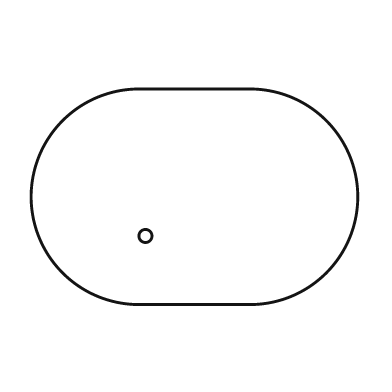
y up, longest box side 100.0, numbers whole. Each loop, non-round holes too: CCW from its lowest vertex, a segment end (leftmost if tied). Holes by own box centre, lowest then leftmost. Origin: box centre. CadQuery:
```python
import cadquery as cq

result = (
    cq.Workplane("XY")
    .moveTo(-17.0, -33.0)
    .lineTo(17.0, -33.0)
    .threePointArc((50.0, 0.0), (17.0, 33.0))
    .lineTo(-17.0, 33.0)
    .threePointArc((-50.0, 0.0), (-17.0, -33.0))
    .close()
    .moveTo(-15.0, -12.0)
    .circle(2.0)
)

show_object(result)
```